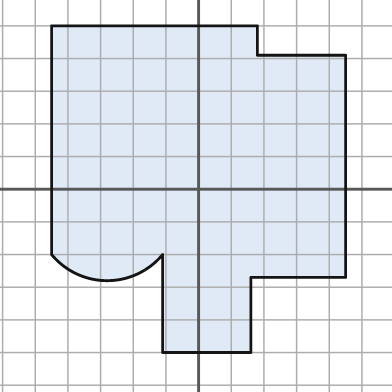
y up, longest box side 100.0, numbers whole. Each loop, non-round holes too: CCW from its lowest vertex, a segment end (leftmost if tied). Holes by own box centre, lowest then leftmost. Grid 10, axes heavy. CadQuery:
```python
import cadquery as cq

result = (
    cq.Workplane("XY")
    .moveTo(-11.0, -50.0)
    .lineTo(16.0, -50.0)
    .lineTo(16.0, -27.0)
    .lineTo(45.0, -27.0)
    .lineTo(45.0, 41.0)
    .lineTo(18.0, 41.0)
    .lineTo(18.0, 50.0)
    .lineTo(-45.0, 50.0)
    .lineTo(-45.0, -20.0)
    .threePointArc((-28.0, -28.0), (-11.0, -20.0))
    .close()
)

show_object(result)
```